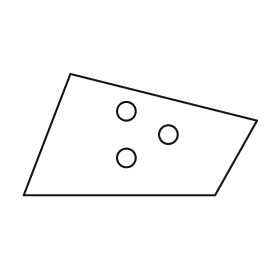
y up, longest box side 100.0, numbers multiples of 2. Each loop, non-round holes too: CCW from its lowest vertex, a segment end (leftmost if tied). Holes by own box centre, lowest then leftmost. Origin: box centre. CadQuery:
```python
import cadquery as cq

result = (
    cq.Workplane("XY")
    .moveTo(-50.0, -26.0)
    .lineTo(32.0, -26.0)
    .lineTo(50.0, 6.0)
    .lineTo(-30.0, 26.0)
    .close()
    .moveTo(-6.0, -10.0)
    .circle(4.0)
    .moveTo(12.0, 0.0)
    .circle(4.0)
    .moveTo(-6.0, 10.0)
    .circle(4.0)
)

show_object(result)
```